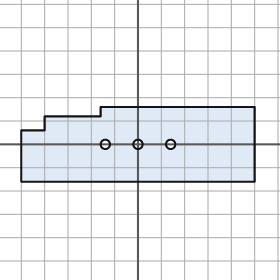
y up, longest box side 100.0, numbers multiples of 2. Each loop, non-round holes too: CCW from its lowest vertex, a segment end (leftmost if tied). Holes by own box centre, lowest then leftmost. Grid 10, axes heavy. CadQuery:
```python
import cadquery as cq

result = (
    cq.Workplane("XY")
    .moveTo(-50.0, -16.0)
    .lineTo(50.0, -16.0)
    .lineTo(50.0, 16.0)
    .lineTo(-16.0, 16.0)
    .lineTo(-16.0, 12.0)
    .lineTo(-40.0, 12.0)
    .lineTo(-40.0, 6.0)
    .lineTo(-50.0, 6.0)
    .close()
    .moveTo(-14.0, 0.0)
    .circle(2.0)
    .moveTo(0.0, 0.0)
    .circle(2.0)
    .moveTo(14.0, 0.0)
    .circle(2.0)
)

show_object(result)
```